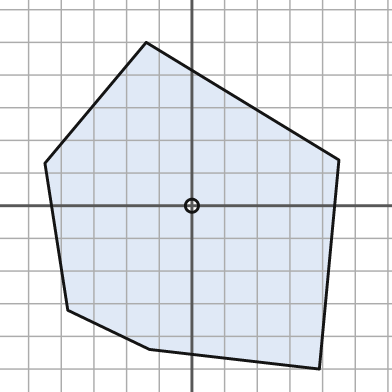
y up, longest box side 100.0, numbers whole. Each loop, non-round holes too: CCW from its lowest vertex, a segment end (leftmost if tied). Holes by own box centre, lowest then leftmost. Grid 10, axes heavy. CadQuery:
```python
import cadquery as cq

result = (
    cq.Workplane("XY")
    .moveTo(39.0, -50.0)
    .lineTo(45.0, 14.0)
    .lineTo(-14.0, 50.0)
    .lineTo(-45.0, 13.0)
    .lineTo(-38.0, -32.0)
    .lineTo(-13.0, -44.0)
    .close()
    .moveTo(0.0, 0.0)
    .circle(2.0)
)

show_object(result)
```